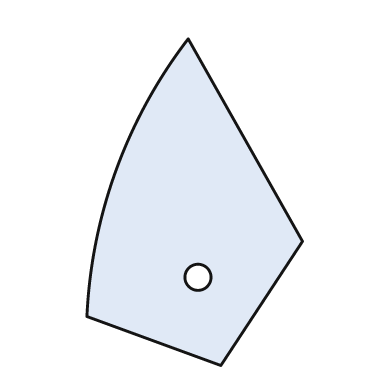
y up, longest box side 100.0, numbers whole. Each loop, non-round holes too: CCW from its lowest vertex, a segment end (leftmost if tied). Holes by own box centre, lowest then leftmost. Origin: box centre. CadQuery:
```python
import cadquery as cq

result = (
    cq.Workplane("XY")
    .moveTo(8.0, -50.0)
    .lineTo(33.0, -12.0)
    .lineTo(-2.0, 50.0)
    .threePointArc((-24.0, 10.0), (-33.0, -35.0))
    .close()
    .moveTo(1.0, -23.0)
    .circle(4.0)
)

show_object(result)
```